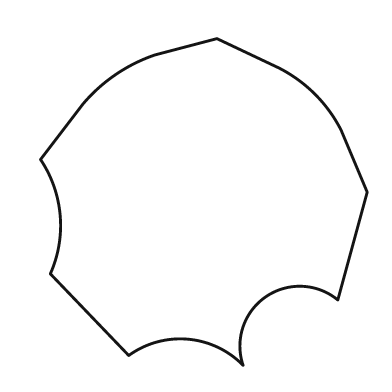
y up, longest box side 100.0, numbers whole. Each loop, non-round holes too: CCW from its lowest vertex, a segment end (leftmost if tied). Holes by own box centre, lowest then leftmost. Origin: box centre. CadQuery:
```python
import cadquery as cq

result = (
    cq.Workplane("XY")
    .moveTo(12.0, -50.0)
    .threePointArc((19.0, -29.0), (41.0, -30.0))
    .lineTo(50.0, 3.0)
    .lineTo(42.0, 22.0)
    .threePointArc((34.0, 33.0), (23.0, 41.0))
    .lineTo(4.0, 50.0)
    .lineTo(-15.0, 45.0)
    .threePointArc((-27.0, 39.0), (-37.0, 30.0))
    .lineTo(-50.0, 13.0)
    .threePointArc((-44.0, -4.0), (-47.0, -22.0))
    .lineTo(-23.0, -47.0)
    .threePointArc((-5.0, -42.0), (12.0, -50.0))
    .close()
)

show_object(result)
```